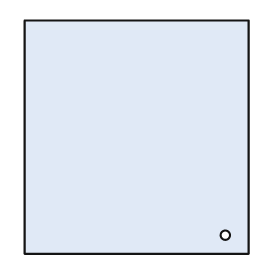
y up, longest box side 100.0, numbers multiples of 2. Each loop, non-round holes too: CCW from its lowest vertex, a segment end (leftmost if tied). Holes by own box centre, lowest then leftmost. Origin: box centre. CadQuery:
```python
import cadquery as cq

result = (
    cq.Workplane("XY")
    .moveTo(-48.0, -50.0)
    .lineTo(48.0, -50.0)
    .lineTo(48.0, 50.0)
    .lineTo(-48.0, 50.0)
    .close()
    .moveTo(38.0, -42.0)
    .circle(2.0)
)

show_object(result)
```